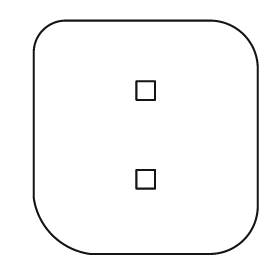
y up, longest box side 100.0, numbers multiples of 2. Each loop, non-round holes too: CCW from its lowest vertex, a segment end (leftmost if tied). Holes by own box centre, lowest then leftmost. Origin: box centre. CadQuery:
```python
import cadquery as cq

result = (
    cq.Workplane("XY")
    .moveTo(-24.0, -50.0)
    .lineTo(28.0, -50.0)
    .threePointArc((42.0, -44.0), (48.0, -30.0))
    .lineTo(48.0, 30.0)
    .threePointArc((42.0, 44.0), (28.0, 50.0))
    .lineTo(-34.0, 50.0)
    .threePointArc((-44.0, 46.0), (-48.0, 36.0))
    .lineTo(-48.0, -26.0)
    .threePointArc((-40.0, -42.0), (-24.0, -50.0))
    .close()
    .moveTo(-4.0, -22.0)
    .lineTo(4.0, -22.0)
    .lineTo(4.0, -14.0)
    .lineTo(-4.0, -14.0)
    .close()
    .moveTo(-4.0, 16.0)
    .lineTo(4.0, 16.0)
    .lineTo(4.0, 24.0)
    .lineTo(-4.0, 24.0)
    .close()
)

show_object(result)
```